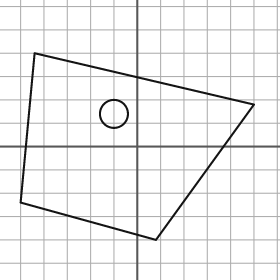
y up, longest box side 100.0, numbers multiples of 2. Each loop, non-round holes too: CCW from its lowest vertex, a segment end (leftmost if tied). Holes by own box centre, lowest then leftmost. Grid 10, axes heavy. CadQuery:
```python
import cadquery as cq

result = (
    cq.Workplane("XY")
    .moveTo(8.0, -40.0)
    .lineTo(50.0, 18.0)
    .lineTo(-44.0, 40.0)
    .lineTo(-50.0, -24.0)
    .close()
    .moveTo(-10.0, 14.0)
    .circle(6.0)
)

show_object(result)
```